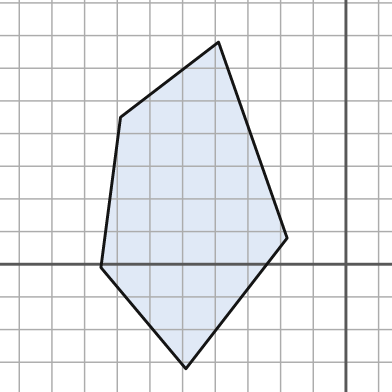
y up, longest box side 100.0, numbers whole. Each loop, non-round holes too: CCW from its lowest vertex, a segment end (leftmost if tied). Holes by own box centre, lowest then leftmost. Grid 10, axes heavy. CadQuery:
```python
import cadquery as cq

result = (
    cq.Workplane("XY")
    .moveTo(-49.0, -32.0)
    .lineTo(-18.0, 8.0)
    .lineTo(-39.0, 68.0)
    .lineTo(-69.0, 45.0)
    .lineTo(-75.0, -1.0)
    .close()
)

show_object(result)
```